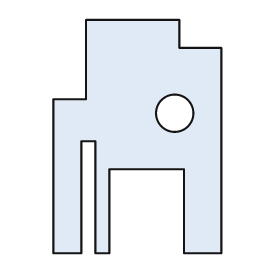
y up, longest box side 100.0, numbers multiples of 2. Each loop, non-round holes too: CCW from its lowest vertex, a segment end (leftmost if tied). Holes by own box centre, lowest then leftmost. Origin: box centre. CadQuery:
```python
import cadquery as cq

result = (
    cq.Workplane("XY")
    .moveTo(-36.0, -50.0)
    .lineTo(-24.0, -50.0)
    .lineTo(-24.0, -2.0)
    .lineTo(-18.0, -2.0)
    .lineTo(-18.0, -50.0)
    .lineTo(-12.0, -50.0)
    .lineTo(-12.0, -14.0)
    .lineTo(20.0, -14.0)
    .lineTo(20.0, -50.0)
    .lineTo(36.0, -50.0)
    .lineTo(36.0, 38.0)
    .lineTo(18.0, 38.0)
    .lineTo(18.0, 50.0)
    .lineTo(-22.0, 50.0)
    .lineTo(-22.0, 16.0)
    .lineTo(-36.0, 16.0)
    .close()
    .moveTo(16.0, 10.0)
    .circle(8.0)
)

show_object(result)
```